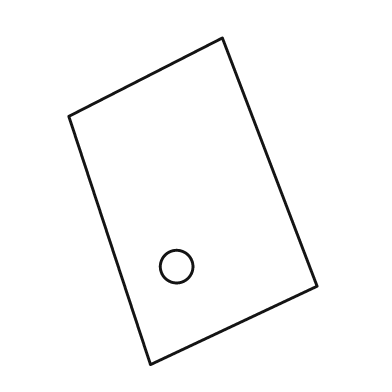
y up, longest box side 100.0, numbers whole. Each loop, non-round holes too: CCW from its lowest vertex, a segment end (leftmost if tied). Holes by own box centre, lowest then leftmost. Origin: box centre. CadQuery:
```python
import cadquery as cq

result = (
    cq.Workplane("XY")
    .moveTo(-13.0, -50.0)
    .lineTo(38.0, -26.0)
    .lineTo(9.0, 50.0)
    .lineTo(-38.0, 26.0)
    .close()
    .moveTo(-5.0, -20.0)
    .circle(5.0)
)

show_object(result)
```